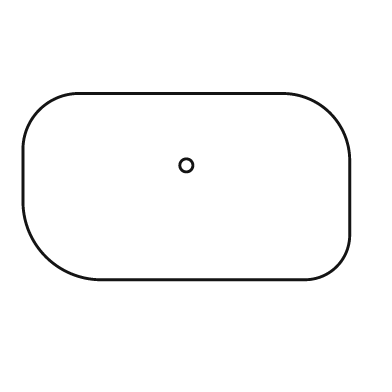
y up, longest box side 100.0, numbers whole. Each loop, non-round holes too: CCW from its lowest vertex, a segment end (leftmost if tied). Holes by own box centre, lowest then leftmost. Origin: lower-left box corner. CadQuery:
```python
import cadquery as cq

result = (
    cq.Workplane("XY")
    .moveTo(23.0, 0.0)
    .lineTo(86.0, 0.0)
    .threePointArc((96.0, 4.0), (100.0, 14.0))
    .lineTo(100.0, 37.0)
    .threePointArc((94.0, 51.0), (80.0, 57.0))
    .lineTo(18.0, 57.0)
    .threePointArc((5.0, 52.0), (0.0, 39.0))
    .lineTo(0.0, 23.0)
    .threePointArc((7.0, 7.0), (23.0, 0.0))
    .close()
    .moveTo(50.0, 35.0)
    .circle(2.0)
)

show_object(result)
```